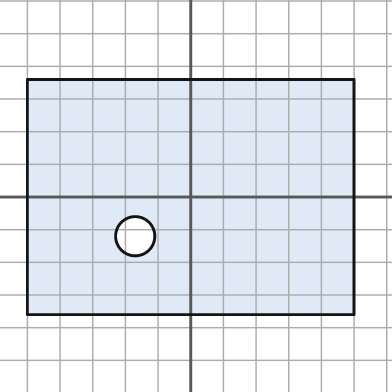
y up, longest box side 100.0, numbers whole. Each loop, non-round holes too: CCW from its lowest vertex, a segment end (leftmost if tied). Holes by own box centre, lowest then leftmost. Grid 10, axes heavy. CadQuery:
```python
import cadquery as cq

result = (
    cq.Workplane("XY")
    .moveTo(-50.0, -36.0)
    .lineTo(50.0, -36.0)
    .lineTo(50.0, 36.0)
    .lineTo(-50.0, 36.0)
    .close()
    .moveTo(-17.0, -12.0)
    .circle(6.0)
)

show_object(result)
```